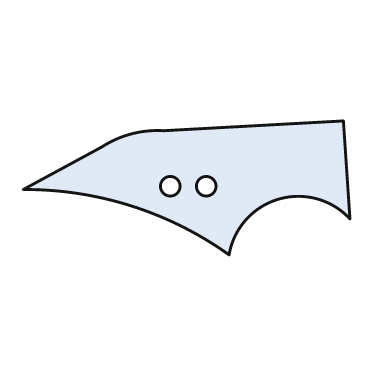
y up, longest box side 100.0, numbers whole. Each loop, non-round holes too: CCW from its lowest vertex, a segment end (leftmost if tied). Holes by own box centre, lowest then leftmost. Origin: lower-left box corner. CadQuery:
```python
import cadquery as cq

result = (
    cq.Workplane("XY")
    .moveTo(63.0, 0.0)
    .threePointArc((78.0, 17.0), (100.0, 11.0))
    .lineTo(98.0, 41.0)
    .lineTo(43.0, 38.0)
    .threePointArc((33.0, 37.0), (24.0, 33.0))
    .lineTo(0.0, 20.0)
    .threePointArc((33.0, 15.0), (63.0, 0.0))
    .close()
    .moveTo(45.0, 21.0)
    .circle(3.0)
    .moveTo(56.0, 21.0)
    .circle(3.0)
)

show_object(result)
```